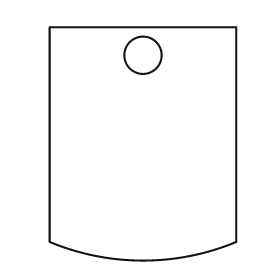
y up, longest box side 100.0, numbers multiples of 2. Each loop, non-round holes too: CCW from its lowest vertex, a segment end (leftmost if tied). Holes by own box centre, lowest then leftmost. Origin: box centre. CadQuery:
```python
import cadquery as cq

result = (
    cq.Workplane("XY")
    .moveTo(-40.0, -42.0)
    .threePointArc((0.0, -50.0), (40.0, -42.0))
    .lineTo(40.0, 50.0)
    .lineTo(-40.0, 50.0)
    .close()
    .moveTo(0.0, 38.0)
    .circle(8.0)
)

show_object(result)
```